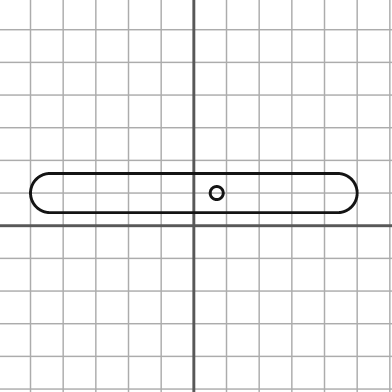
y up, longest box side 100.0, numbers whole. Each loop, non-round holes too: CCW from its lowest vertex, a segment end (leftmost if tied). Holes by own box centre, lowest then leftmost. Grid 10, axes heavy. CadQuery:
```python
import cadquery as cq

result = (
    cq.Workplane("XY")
    .moveTo(-44.0, 4.0)
    .lineTo(44.0, 4.0)
    .threePointArc((50.0, 10.0), (44.0, 16.0))
    .lineTo(-44.0, 16.0)
    .threePointArc((-50.0, 10.0), (-44.0, 4.0))
    .close()
    .moveTo(7.0, 10.0)
    .circle(2.0)
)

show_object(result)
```